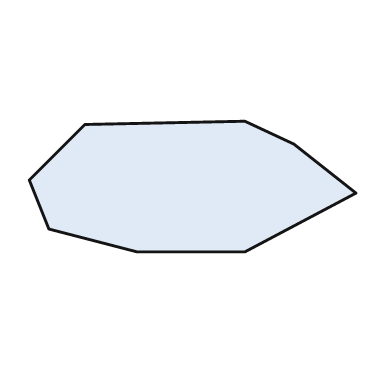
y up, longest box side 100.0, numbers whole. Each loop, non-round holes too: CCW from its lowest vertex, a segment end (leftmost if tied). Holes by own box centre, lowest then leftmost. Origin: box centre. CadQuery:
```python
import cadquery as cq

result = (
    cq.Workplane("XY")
    .moveTo(-17.0, -20.0)
    .lineTo(16.0, -20.0)
    .lineTo(50.0, -2.0)
    .lineTo(31.0, 13.0)
    .lineTo(16.0, 20.0)
    .lineTo(-33.0, 19.0)
    .lineTo(-50.0, 2.0)
    .lineTo(-44.0, -13.0)
    .close()
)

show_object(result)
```